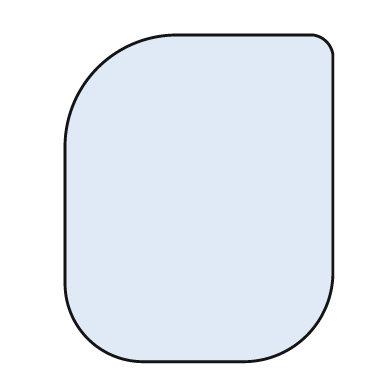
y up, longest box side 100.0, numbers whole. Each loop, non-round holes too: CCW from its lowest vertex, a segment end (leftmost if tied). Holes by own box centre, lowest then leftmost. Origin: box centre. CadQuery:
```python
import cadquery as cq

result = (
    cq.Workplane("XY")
    .moveTo(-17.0, -50.0)
    .lineTo(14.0, -50.0)
    .threePointArc((33.0, -42.0), (41.0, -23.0))
    .lineTo(41.0, 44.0)
    .threePointArc((39.0, 48.0), (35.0, 50.0))
    .lineTo(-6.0, 50.0)
    .threePointArc((-31.0, 40.0), (-41.0, 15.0))
    .lineTo(-41.0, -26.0)
    .threePointArc((-34.0, -43.0), (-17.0, -50.0))
    .close()
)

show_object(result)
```